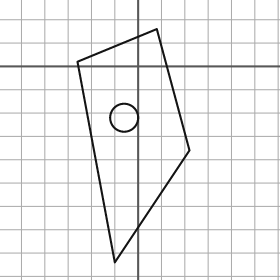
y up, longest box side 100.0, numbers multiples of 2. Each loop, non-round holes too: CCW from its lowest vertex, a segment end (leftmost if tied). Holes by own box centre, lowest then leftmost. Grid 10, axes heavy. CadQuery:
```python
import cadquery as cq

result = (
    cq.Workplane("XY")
    .moveTo(-10.0, -84.0)
    .lineTo(22.0, -36.0)
    .lineTo(8.0, 16.0)
    .lineTo(-26.0, 2.0)
    .close()
    .moveTo(-6.0, -22.0)
    .circle(6.0)
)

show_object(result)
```